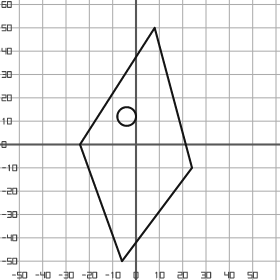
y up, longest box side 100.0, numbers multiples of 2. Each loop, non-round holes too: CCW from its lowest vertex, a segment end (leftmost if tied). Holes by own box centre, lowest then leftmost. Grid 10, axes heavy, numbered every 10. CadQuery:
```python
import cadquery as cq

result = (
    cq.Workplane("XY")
    .moveTo(-6.0, -50.0)
    .lineTo(24.0, -10.0)
    .lineTo(8.0, 50.0)
    .lineTo(-24.0, 0.0)
    .close()
    .moveTo(-4.0, 12.0)
    .circle(4.0)
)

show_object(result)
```